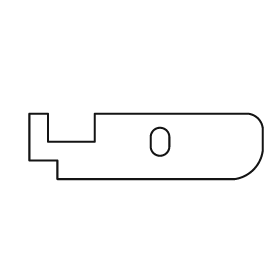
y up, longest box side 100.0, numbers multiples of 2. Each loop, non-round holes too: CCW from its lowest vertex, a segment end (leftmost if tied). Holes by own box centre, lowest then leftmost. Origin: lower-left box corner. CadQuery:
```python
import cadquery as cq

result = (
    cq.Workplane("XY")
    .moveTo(12.0, 0.0)
    .lineTo(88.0, 0.0)
    .threePointArc((96.0, 4.0), (100.0, 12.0))
    .lineTo(100.0, 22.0)
    .threePointArc((98.0, 26.0), (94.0, 28.0))
    .lineTo(28.0, 28.0)
    .lineTo(28.0, 16.0)
    .lineTo(8.0, 16.0)
    .lineTo(8.0, 28.0)
    .lineTo(0.0, 28.0)
    .lineTo(0.0, 8.0)
    .lineTo(12.0, 8.0)
    .close()
    .moveTo(52.0, 14.0)
    .threePointArc((56.0, 10.0), (60.0, 14.0))
    .lineTo(60.0, 18.0)
    .threePointArc((56.0, 22.0), (52.0, 18.0))
    .close()
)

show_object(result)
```